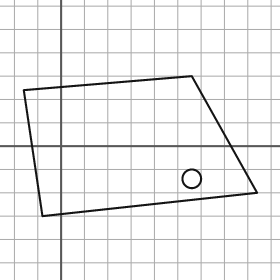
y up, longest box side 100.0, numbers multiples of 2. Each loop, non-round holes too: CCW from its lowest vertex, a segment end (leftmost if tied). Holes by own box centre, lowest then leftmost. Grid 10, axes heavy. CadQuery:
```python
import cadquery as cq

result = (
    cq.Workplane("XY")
    .moveTo(-8.0, -30.0)
    .lineTo(84.0, -20.0)
    .lineTo(56.0, 30.0)
    .lineTo(-16.0, 24.0)
    .close()
    .moveTo(56.0, -14.0)
    .circle(4.0)
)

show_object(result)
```